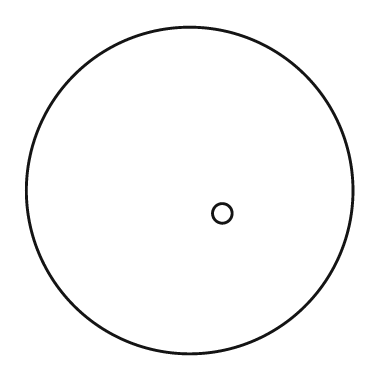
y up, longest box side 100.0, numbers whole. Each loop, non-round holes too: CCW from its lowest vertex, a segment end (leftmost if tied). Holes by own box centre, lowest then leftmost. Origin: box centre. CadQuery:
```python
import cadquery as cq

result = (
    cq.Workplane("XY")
    .moveTo(0.0, 0.0)
    .circle(50.0)
    .moveTo(10.0, -7.0)
    .circle(3.0)
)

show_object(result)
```